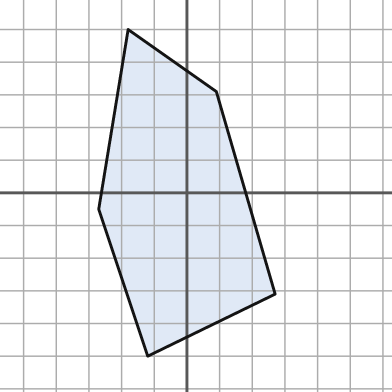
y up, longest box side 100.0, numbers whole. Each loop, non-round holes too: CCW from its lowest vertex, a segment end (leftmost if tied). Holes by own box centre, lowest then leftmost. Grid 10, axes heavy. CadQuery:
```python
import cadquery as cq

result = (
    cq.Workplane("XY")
    .moveTo(-12.0, -50.0)
    .lineTo(27.0, -31.0)
    .lineTo(9.0, 31.0)
    .lineTo(-18.0, 50.0)
    .lineTo(-27.0, -5.0)
    .close()
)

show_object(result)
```